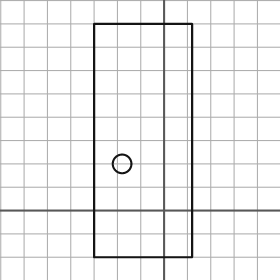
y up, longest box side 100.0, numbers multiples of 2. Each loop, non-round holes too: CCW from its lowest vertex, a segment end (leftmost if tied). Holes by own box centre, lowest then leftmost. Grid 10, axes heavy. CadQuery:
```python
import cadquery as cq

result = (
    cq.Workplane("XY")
    .moveTo(-30.0, -20.0)
    .lineTo(12.0, -20.0)
    .lineTo(12.0, 80.0)
    .lineTo(-30.0, 80.0)
    .close()
    .moveTo(-18.0, 20.0)
    .circle(4.0)
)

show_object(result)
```